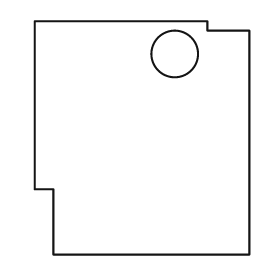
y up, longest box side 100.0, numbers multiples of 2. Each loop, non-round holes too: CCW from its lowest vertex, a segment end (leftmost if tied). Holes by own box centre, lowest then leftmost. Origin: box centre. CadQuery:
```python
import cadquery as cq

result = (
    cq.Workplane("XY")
    .moveTo(-38.0, -50.0)
    .lineTo(46.0, -50.0)
    .lineTo(46.0, 46.0)
    .lineTo(28.0, 46.0)
    .lineTo(28.0, 50.0)
    .lineTo(-46.0, 50.0)
    .lineTo(-46.0, -22.0)
    .lineTo(-38.0, -22.0)
    .close()
    .moveTo(14.0, 36.0)
    .circle(10.0)
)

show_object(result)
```